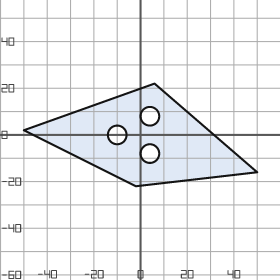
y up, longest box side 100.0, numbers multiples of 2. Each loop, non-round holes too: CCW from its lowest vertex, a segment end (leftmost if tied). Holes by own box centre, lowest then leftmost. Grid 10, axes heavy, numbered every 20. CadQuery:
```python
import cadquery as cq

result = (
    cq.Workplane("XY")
    .moveTo(-2.0, -22.0)
    .lineTo(50.0, -16.0)
    .lineTo(6.0, 22.0)
    .lineTo(-50.0, 2.0)
    .close()
    .moveTo(4.0, -8.0)
    .circle(4.0)
    .moveTo(-10.0, 0.0)
    .circle(4.0)
    .moveTo(4.0, 8.0)
    .circle(4.0)
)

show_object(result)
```